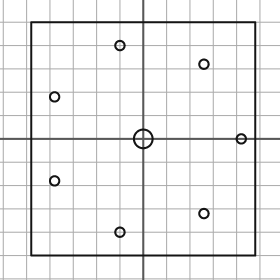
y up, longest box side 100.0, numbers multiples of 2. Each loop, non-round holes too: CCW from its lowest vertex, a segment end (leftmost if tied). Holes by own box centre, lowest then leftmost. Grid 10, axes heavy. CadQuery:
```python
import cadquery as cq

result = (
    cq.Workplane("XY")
    .moveTo(-48.0, -50.0)
    .lineTo(48.0, -50.0)
    .lineTo(48.0, 50.0)
    .lineTo(-48.0, 50.0)
    .close()
    .moveTo(-10.0, -40.0)
    .circle(2.0)
    .moveTo(26.0, -32.0)
    .circle(2.0)
    .moveTo(-38.0, -18.0)
    .circle(2.0)
    .moveTo(0.0, 0.0)
    .circle(4.0)
    .moveTo(42.0, 0.0)
    .circle(2.0)
    .moveTo(-38.0, 18.0)
    .circle(2.0)
    .moveTo(26.0, 32.0)
    .circle(2.0)
    .moveTo(-10.0, 40.0)
    .circle(2.0)
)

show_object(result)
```